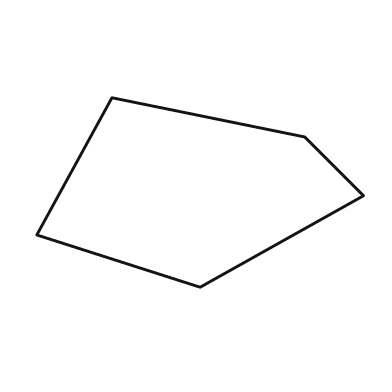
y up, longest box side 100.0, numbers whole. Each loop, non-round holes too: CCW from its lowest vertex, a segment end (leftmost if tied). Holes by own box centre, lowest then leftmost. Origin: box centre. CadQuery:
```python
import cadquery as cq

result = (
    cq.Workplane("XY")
    .moveTo(0.0, -29.0)
    .lineTo(50.0, -1.0)
    .lineTo(32.0, 17.0)
    .lineTo(-27.0, 29.0)
    .lineTo(-50.0, -13.0)
    .close()
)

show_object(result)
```